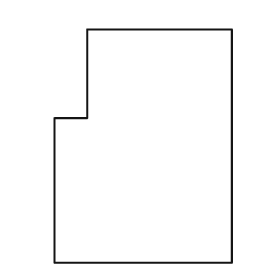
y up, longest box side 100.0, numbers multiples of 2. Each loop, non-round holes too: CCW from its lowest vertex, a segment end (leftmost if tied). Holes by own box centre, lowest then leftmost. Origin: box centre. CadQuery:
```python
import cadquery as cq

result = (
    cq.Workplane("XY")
    .moveTo(-38.0, -50.0)
    .lineTo(38.0, -50.0)
    .lineTo(38.0, 50.0)
    .lineTo(-24.0, 50.0)
    .lineTo(-24.0, 12.0)
    .lineTo(-38.0, 12.0)
    .close()
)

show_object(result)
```